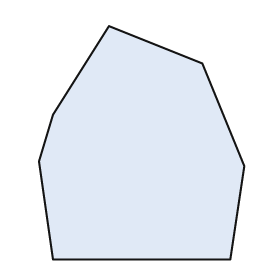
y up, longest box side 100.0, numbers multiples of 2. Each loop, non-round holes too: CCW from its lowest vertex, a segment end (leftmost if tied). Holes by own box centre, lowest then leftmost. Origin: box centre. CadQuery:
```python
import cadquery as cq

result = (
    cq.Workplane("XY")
    .moveTo(-38.0, -50.0)
    .lineTo(38.0, -50.0)
    .lineTo(44.0, -10.0)
    .lineTo(26.0, 34.0)
    .lineTo(-14.0, 50.0)
    .lineTo(-38.0, 12.0)
    .lineTo(-44.0, -8.0)
    .close()
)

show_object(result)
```